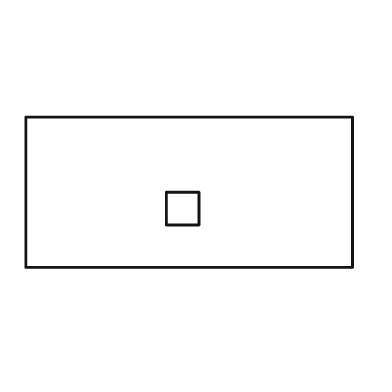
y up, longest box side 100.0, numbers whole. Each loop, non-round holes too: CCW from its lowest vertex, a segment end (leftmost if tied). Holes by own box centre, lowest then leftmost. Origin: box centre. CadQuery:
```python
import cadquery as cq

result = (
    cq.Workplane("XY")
    .moveTo(-50.0, -23.0)
    .lineTo(50.0, -23.0)
    .lineTo(50.0, 23.0)
    .lineTo(-50.0, 23.0)
    .close()
    .moveTo(-7.0, -10.0)
    .lineTo(3.0, -10.0)
    .lineTo(3.0, 0.0)
    .lineTo(-7.0, 0.0)
    .close()
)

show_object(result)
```